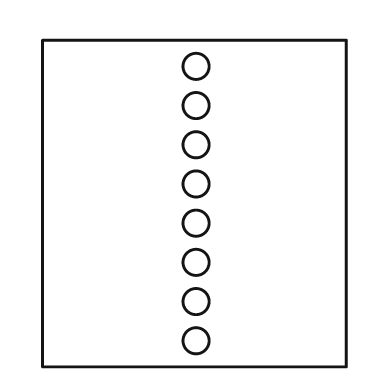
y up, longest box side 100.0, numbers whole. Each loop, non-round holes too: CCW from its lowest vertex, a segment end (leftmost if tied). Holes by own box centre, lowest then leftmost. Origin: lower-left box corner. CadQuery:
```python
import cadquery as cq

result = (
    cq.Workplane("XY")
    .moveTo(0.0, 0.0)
    .lineTo(93.0, 0.0)
    .lineTo(93.0, 100.0)
    .lineTo(0.0, 100.0)
    .close()
    .moveTo(47.0, 8.0)
    .circle(4.0)
    .moveTo(47.0, 20.0)
    .circle(4.0)
    .moveTo(47.0, 32.0)
    .circle(4.0)
    .moveTo(47.0, 44.0)
    .circle(4.0)
    .moveTo(47.0, 56.0)
    .circle(4.0)
    .moveTo(47.0, 68.0)
    .circle(4.0)
    .moveTo(47.0, 80.0)
    .circle(4.0)
    .moveTo(47.0, 92.0)
    .circle(4.0)
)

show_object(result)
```